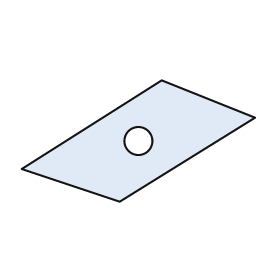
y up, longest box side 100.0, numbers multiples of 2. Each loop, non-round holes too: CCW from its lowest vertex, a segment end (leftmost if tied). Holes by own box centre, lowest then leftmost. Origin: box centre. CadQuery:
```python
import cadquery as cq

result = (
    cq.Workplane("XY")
    .moveTo(-8.0, -26.0)
    .lineTo(50.0, 10.0)
    .lineTo(10.0, 26.0)
    .lineTo(-50.0, -12.0)
    .close()
    .moveTo(0.0, 0.0)
    .circle(6.0)
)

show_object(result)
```